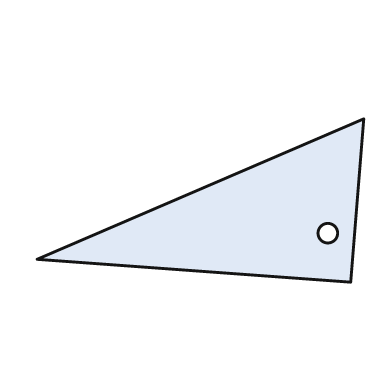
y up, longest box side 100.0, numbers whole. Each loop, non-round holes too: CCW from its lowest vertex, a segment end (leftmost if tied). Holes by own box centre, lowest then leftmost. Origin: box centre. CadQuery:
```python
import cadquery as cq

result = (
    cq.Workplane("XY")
    .moveTo(46.0, -25.0)
    .lineTo(50.0, 25.0)
    .lineTo(-50.0, -18.0)
    .close()
    .moveTo(39.0, -10.0)
    .circle(3.0)
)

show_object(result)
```